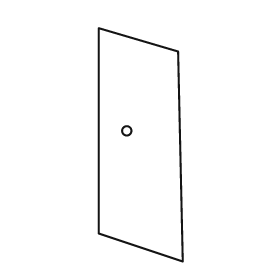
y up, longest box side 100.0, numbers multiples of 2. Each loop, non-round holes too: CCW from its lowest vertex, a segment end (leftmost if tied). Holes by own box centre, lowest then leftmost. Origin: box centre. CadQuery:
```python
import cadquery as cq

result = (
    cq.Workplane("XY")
    .moveTo(18.0, -50.0)
    .lineTo(16.0, 40.0)
    .lineTo(-18.0, 50.0)
    .lineTo(-18.0, -38.0)
    .close()
    .moveTo(-6.0, 6.0)
    .circle(2.0)
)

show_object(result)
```